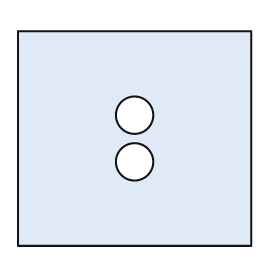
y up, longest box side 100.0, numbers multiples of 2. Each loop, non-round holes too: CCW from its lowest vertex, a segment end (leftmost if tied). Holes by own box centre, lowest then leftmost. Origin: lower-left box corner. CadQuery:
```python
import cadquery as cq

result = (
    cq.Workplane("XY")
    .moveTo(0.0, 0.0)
    .lineTo(100.0, 0.0)
    .lineTo(100.0, 92.0)
    .lineTo(0.0, 92.0)
    .close()
    .moveTo(50.0, 36.0)
    .circle(8.0)
    .moveTo(50.0, 56.0)
    .circle(8.0)
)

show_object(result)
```